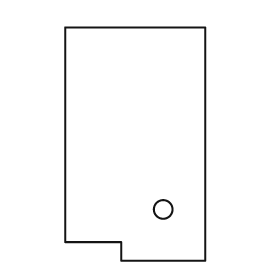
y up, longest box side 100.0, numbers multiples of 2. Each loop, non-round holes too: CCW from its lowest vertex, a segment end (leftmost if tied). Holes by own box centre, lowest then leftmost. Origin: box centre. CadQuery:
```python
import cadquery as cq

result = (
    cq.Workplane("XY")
    .moveTo(-6.0, -50.0)
    .lineTo(30.0, -50.0)
    .lineTo(30.0, 50.0)
    .lineTo(-30.0, 50.0)
    .lineTo(-30.0, -42.0)
    .lineTo(-6.0, -42.0)
    .close()
    .moveTo(12.0, -28.0)
    .circle(4.0)
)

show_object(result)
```